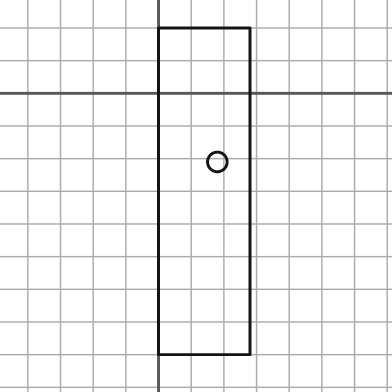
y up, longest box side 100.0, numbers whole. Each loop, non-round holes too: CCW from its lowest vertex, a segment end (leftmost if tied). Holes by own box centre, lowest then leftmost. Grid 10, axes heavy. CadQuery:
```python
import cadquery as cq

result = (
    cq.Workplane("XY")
    .moveTo(0.0, -80.0)
    .lineTo(28.0, -80.0)
    .lineTo(28.0, 20.0)
    .lineTo(0.0, 20.0)
    .close()
    .moveTo(18.0, -21.0)
    .circle(3.0)
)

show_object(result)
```